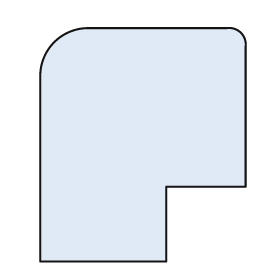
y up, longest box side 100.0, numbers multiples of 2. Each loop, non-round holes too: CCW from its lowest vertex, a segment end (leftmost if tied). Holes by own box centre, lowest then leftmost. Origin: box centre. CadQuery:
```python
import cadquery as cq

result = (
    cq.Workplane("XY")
    .moveTo(-44.0, -50.0)
    .lineTo(10.0, -50.0)
    .lineTo(10.0, -18.0)
    .lineTo(44.0, -18.0)
    .lineTo(44.0, 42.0)
    .threePointArc((42.0, 48.0), (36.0, 50.0))
    .lineTo(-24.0, 50.0)
    .threePointArc((-38.0, 44.0), (-44.0, 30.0))
    .close()
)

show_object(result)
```